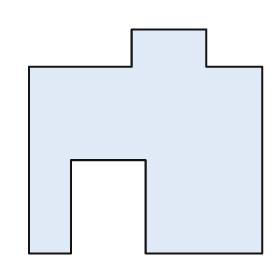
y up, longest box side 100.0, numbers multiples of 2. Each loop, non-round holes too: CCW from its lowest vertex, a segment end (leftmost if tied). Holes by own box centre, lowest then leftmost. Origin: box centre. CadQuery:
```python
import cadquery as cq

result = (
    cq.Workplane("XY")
    .moveTo(-50.0, -48.0)
    .lineTo(-32.0, -48.0)
    .lineTo(-32.0, -8.0)
    .lineTo(0.0, -8.0)
    .lineTo(0.0, -48.0)
    .lineTo(50.0, -48.0)
    .lineTo(50.0, 32.0)
    .lineTo(26.0, 32.0)
    .lineTo(26.0, 48.0)
    .lineTo(-6.0, 48.0)
    .lineTo(-6.0, 32.0)
    .lineTo(-50.0, 32.0)
    .close()
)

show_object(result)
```